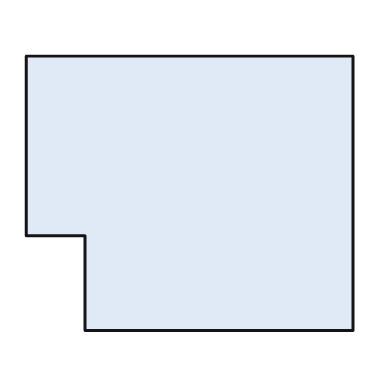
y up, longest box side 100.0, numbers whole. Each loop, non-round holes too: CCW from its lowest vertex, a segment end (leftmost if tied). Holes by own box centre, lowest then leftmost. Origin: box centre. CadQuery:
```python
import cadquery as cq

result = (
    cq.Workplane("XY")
    .moveTo(-32.0, -42.0)
    .lineTo(50.0, -42.0)
    .lineTo(50.0, 42.0)
    .lineTo(-50.0, 42.0)
    .lineTo(-50.0, -13.0)
    .lineTo(-32.0, -13.0)
    .close()
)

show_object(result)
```